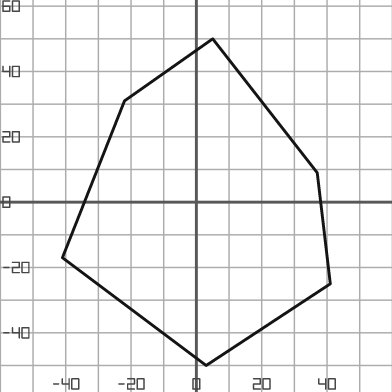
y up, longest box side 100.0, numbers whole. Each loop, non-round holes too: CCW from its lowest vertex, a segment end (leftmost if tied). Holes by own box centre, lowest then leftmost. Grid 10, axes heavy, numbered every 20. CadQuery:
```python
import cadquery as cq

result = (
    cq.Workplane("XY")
    .moveTo(3.0, -50.0)
    .lineTo(41.0, -25.0)
    .lineTo(37.0, 9.0)
    .lineTo(5.0, 50.0)
    .lineTo(-22.0, 31.0)
    .lineTo(-41.0, -17.0)
    .close()
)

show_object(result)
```